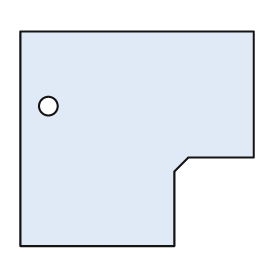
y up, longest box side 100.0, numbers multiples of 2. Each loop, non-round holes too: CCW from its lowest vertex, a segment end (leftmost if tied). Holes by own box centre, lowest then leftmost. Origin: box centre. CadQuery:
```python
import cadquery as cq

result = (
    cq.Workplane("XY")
    .moveTo(-50.0, -46.0)
    .lineTo(16.0, -46.0)
    .lineTo(16.0, -14.0)
    .lineTo(22.0, -8.0)
    .lineTo(50.0, -8.0)
    .lineTo(50.0, 46.0)
    .lineTo(-50.0, 46.0)
    .close()
    .moveTo(-38.0, 14.0)
    .circle(4.0)
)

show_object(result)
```